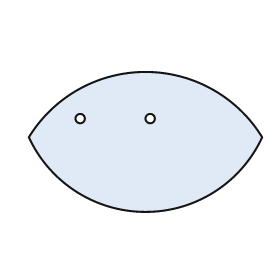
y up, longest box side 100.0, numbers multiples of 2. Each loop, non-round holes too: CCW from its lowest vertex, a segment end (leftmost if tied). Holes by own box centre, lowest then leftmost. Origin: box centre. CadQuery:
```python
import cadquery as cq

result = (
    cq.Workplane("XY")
    .moveTo(-50.0, 2.0)
    .threePointArc((0.0, -30.0), (50.0, 2.0))
    .threePointArc((0.0, 30.0), (-50.0, 2.0))
    .close()
    .moveTo(-28.0, 10.0)
    .circle(2.0)
    .moveTo(2.0, 10.0)
    .circle(2.0)
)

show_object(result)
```